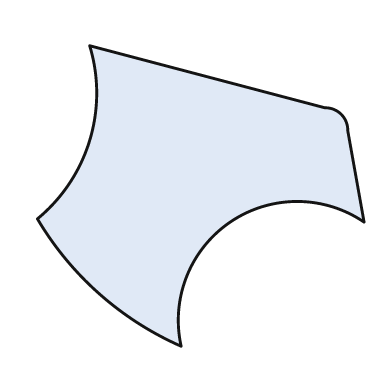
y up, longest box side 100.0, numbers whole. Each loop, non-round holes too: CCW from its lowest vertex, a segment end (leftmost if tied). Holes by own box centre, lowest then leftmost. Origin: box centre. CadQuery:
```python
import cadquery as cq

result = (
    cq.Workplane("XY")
    .moveTo(-6.0, -46.0)
    .threePointArc((9.0, -8.0), (50.0, -8.0))
    .lineTo(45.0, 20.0)
    .threePointArc((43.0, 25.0), (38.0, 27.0))
    .lineTo(-34.0, 46.0)
    .threePointArc((-34.0, 17.0), (-50.0, -7.0))
    .threePointArc((-31.0, -30.0), (-6.0, -46.0))
    .close()
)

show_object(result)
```